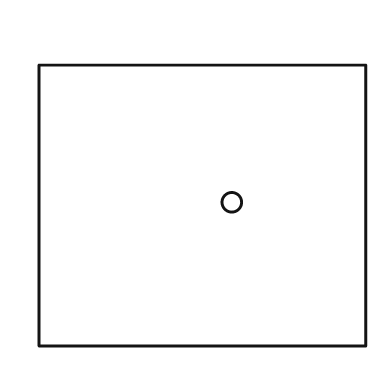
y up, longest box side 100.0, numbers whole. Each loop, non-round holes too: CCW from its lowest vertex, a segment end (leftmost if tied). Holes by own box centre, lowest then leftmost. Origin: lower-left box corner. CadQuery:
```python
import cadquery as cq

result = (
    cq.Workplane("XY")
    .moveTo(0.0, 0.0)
    .lineTo(100.0, 0.0)
    .lineTo(100.0, 86.0)
    .lineTo(0.0, 86.0)
    .close()
    .moveTo(59.0, 44.0)
    .circle(3.0)
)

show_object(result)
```